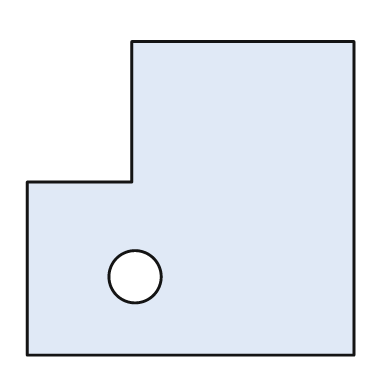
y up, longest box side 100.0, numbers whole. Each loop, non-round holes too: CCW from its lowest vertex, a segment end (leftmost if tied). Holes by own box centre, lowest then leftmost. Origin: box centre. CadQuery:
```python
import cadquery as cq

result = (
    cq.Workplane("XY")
    .moveTo(-50.0, -48.0)
    .lineTo(50.0, -48.0)
    .lineTo(50.0, 48.0)
    .lineTo(-18.0, 48.0)
    .lineTo(-18.0, 5.0)
    .lineTo(-50.0, 5.0)
    .close()
    .moveTo(-17.0, -24.0)
    .circle(8.0)
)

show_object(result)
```